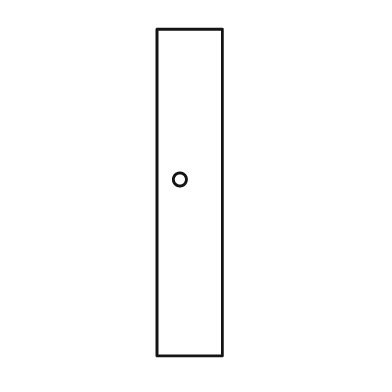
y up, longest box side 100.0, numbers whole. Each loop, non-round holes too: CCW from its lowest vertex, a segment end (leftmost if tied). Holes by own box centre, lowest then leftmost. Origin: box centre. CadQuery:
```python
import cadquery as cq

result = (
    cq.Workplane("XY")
    .moveTo(-10.0, -50.0)
    .lineTo(10.0, -50.0)
    .lineTo(10.0, 50.0)
    .lineTo(-10.0, 50.0)
    .close()
    .moveTo(-3.0, 4.0)
    .circle(2.0)
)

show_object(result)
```